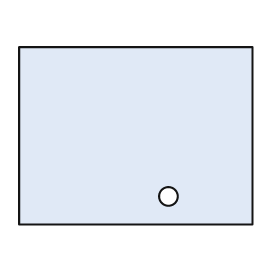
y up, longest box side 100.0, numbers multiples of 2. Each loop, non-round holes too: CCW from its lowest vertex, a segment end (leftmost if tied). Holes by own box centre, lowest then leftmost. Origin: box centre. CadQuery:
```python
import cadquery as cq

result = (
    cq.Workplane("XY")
    .moveTo(-50.0, -38.0)
    .lineTo(50.0, -38.0)
    .lineTo(50.0, 38.0)
    .lineTo(-50.0, 38.0)
    .close()
    .moveTo(14.0, -26.0)
    .circle(4.0)
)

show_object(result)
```